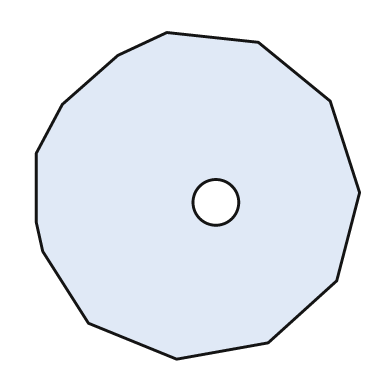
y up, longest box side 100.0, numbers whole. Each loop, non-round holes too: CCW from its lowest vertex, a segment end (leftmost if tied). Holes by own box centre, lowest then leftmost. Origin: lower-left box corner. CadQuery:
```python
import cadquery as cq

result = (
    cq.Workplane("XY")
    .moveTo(43.0, 0.0)
    .lineTo(71.0, 5.0)
    .lineTo(92.0, 24.0)
    .lineTo(99.0, 51.0)
    .lineTo(90.0, 79.0)
    .lineTo(68.0, 97.0)
    .lineTo(40.0, 100.0)
    .lineTo(25.0, 93.0)
    .lineTo(8.0, 78.0)
    .lineTo(0.0, 63.0)
    .lineTo(0.0, 42.0)
    .lineTo(2.0, 33.0)
    .lineTo(16.0, 11.0)
    .close()
    .moveTo(55.0, 48.0)
    .circle(7.0)
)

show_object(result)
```